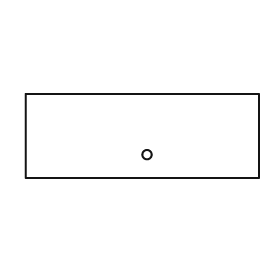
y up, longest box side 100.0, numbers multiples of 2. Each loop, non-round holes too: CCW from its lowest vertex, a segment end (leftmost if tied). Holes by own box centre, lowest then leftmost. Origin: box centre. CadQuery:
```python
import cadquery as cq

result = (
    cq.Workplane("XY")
    .moveTo(-50.0, -18.0)
    .lineTo(50.0, -18.0)
    .lineTo(50.0, 18.0)
    .lineTo(-50.0, 18.0)
    .close()
    .moveTo(2.0, -8.0)
    .circle(2.0)
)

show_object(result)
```